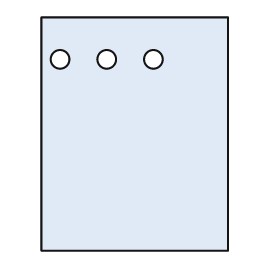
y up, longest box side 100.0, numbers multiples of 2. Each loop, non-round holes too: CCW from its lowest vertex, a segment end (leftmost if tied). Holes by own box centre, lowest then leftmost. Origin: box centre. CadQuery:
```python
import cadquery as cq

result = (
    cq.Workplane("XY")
    .moveTo(-40.0, -50.0)
    .lineTo(40.0, -50.0)
    .lineTo(40.0, 50.0)
    .lineTo(-40.0, 50.0)
    .close()
    .moveTo(-32.0, 32.0)
    .circle(4.0)
    .moveTo(-12.0, 32.0)
    .circle(4.0)
    .moveTo(8.0, 32.0)
    .circle(4.0)
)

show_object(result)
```